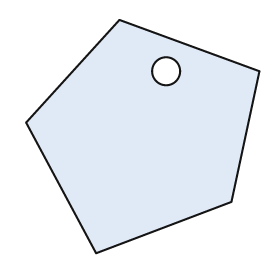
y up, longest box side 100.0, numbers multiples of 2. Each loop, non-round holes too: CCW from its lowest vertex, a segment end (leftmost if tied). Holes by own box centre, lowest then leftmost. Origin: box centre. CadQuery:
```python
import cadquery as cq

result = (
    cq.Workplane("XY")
    .moveTo(-20.0, -50.0)
    .lineTo(38.0, -28.0)
    .lineTo(50.0, 28.0)
    .lineTo(-10.0, 50.0)
    .lineTo(-50.0, 6.0)
    .close()
    .moveTo(10.0, 28.0)
    .circle(6.0)
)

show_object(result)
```